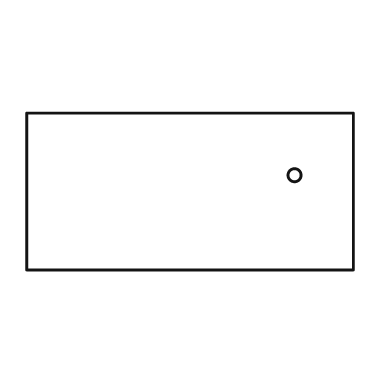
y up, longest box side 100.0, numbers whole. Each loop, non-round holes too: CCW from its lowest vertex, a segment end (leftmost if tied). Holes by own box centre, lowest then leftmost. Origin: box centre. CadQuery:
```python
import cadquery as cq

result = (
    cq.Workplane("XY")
    .moveTo(-50.0, -24.0)
    .lineTo(50.0, -24.0)
    .lineTo(50.0, 24.0)
    .lineTo(-50.0, 24.0)
    .close()
    .moveTo(32.0, 5.0)
    .circle(2.0)
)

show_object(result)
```